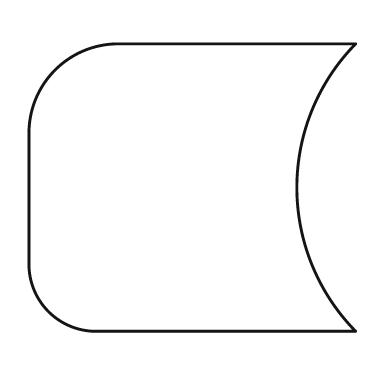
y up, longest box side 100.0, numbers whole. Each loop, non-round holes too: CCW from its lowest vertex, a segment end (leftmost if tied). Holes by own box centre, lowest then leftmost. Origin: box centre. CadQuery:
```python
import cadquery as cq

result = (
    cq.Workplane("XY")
    .moveTo(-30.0, -44.0)
    .lineTo(50.0, -44.0)
    .threePointArc((32.0, 0.0), (50.0, 44.0))
    .lineTo(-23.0, 44.0)
    .threePointArc((-42.0, 36.0), (-50.0, 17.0))
    .lineTo(-50.0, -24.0)
    .threePointArc((-44.0, -38.0), (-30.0, -44.0))
    .close()
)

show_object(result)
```